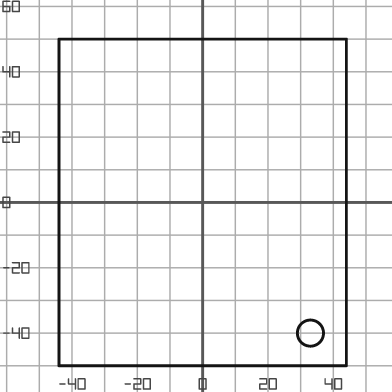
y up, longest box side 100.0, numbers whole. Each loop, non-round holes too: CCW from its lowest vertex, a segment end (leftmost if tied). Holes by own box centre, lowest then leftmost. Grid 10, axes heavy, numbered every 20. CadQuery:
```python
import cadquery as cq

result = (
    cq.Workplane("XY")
    .moveTo(-44.0, -50.0)
    .lineTo(44.0, -50.0)
    .lineTo(44.0, 50.0)
    .lineTo(-44.0, 50.0)
    .close()
    .moveTo(33.0, -40.0)
    .circle(4.0)
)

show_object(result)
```